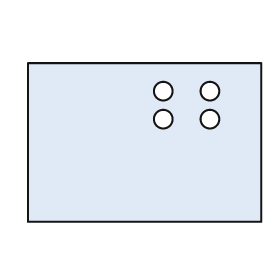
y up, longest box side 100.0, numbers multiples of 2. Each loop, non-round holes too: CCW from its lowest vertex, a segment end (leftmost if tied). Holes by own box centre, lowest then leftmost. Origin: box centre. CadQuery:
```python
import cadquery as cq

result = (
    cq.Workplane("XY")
    .moveTo(-50.0, -34.0)
    .lineTo(50.0, -34.0)
    .lineTo(50.0, 34.0)
    .lineTo(-50.0, 34.0)
    .close()
    .moveTo(8.0, 10.0)
    .circle(4.0)
    .moveTo(28.0, 10.0)
    .circle(4.0)
    .moveTo(8.0, 22.0)
    .circle(4.0)
    .moveTo(28.0, 22.0)
    .circle(4.0)
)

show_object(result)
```